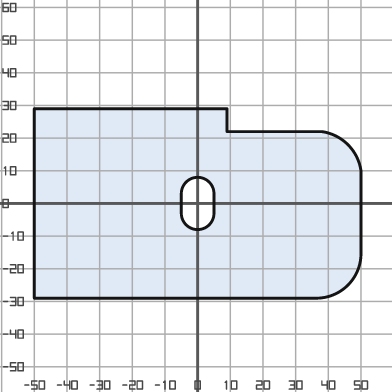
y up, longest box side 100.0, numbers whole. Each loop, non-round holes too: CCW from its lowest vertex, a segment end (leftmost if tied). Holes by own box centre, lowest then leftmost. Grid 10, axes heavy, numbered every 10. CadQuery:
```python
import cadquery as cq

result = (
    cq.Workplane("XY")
    .moveTo(-50.0, -29.0)
    .lineTo(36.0, -29.0)
    .threePointArc((46.0, -25.0), (50.0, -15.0))
    .lineTo(50.0, 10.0)
    .threePointArc((46.0, 18.0), (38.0, 22.0))
    .lineTo(9.0, 22.0)
    .lineTo(9.0, 29.0)
    .lineTo(-50.0, 29.0)
    .close()
    .moveTo(-5.0, -3.0)
    .threePointArc((0.0, -8.0), (5.0, -3.0))
    .lineTo(5.0, 3.0)
    .threePointArc((0.0, 8.0), (-5.0, 3.0))
    .close()
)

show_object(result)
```